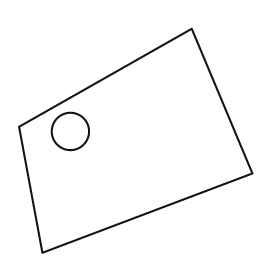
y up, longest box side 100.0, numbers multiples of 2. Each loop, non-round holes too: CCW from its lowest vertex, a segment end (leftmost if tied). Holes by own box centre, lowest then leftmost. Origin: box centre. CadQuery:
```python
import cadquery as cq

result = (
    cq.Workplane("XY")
    .moveTo(-40.0, -48.0)
    .lineTo(50.0, -14.0)
    .lineTo(24.0, 48.0)
    .lineTo(-50.0, 6.0)
    .close()
    .moveTo(-28.0, 4.0)
    .circle(8.0)
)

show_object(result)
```